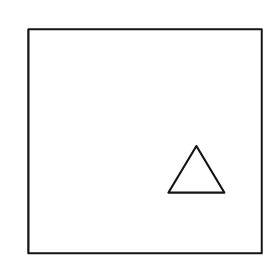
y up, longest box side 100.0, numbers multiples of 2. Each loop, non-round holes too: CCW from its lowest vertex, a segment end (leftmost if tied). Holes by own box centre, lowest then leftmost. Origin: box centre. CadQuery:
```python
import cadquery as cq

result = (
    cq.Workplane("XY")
    .moveTo(-50.0, -48.0)
    .lineTo(50.0, -48.0)
    .lineTo(50.0, 48.0)
    .lineTo(-50.0, 48.0)
    .close()
    .moveTo(10.0, -22.0)
    .lineTo(34.0, -22.0)
    .lineTo(22.0, -2.0)
    .close()
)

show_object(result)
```